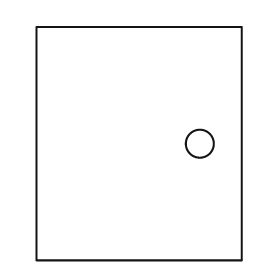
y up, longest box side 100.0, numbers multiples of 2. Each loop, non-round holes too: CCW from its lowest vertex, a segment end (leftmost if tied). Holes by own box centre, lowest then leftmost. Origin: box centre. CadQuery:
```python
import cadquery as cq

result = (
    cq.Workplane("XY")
    .moveTo(-44.0, -50.0)
    .lineTo(44.0, -50.0)
    .lineTo(44.0, 50.0)
    .lineTo(-44.0, 50.0)
    .close()
    .moveTo(26.0, 0.0)
    .circle(6.0)
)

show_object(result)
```